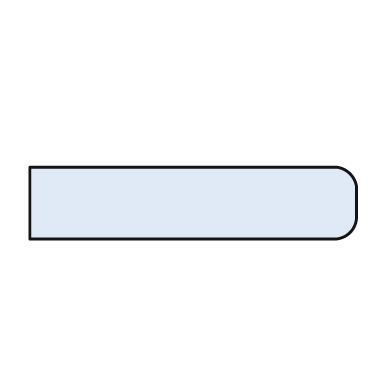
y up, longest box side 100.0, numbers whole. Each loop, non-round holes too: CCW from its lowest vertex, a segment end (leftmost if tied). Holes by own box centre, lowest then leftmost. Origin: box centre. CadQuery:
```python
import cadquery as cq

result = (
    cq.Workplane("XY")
    .moveTo(-50.0, -11.0)
    .lineTo(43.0, -11.0)
    .threePointArc((48.0, -9.0), (50.0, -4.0))
    .lineTo(50.0, 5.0)
    .threePointArc((48.0, 9.0), (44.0, 11.0))
    .lineTo(-50.0, 11.0)
    .close()
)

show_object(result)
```